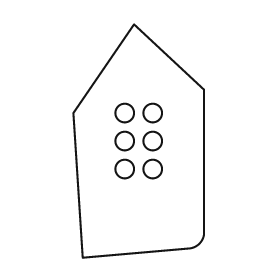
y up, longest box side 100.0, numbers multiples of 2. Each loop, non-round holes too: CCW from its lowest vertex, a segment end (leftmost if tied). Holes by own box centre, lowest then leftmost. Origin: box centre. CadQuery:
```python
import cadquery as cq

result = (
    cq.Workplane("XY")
    .moveTo(-24.0, -50.0)
    .lineTo(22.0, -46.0)
    .threePointArc((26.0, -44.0), (28.0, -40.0))
    .lineTo(28.0, 22.0)
    .lineTo(-2.0, 50.0)
    .lineTo(-28.0, 12.0)
    .close()
    .moveTo(-6.0, -12.0)
    .circle(4.0)
    .moveTo(6.0, -12.0)
    .circle(4.0)
    .moveTo(-6.0, 0.0)
    .circle(4.0)
    .moveTo(6.0, 0.0)
    .circle(4.0)
    .moveTo(-6.0, 12.0)
    .circle(4.0)
    .moveTo(6.0, 12.0)
    .circle(4.0)
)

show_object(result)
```